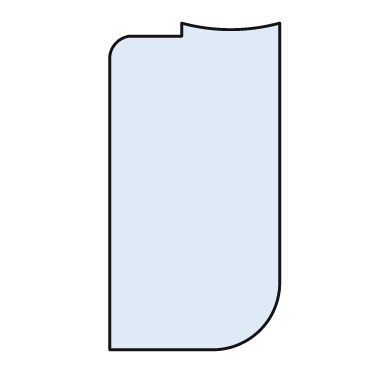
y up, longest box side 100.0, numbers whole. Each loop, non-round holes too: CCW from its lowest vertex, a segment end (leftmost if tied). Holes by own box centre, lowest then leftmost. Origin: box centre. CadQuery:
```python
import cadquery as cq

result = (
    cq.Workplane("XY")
    .moveTo(-26.0, -50.0)
    .lineTo(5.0, -50.0)
    .threePointArc((20.0, -44.0), (26.0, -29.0))
    .lineTo(26.0, 50.0)
    .threePointArc((11.0, 48.0), (-4.0, 50.0))
    .lineTo(-4.0, 46.0)
    .lineTo(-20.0, 46.0)
    .threePointArc((-24.0, 44.0), (-26.0, 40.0))
    .close()
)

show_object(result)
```